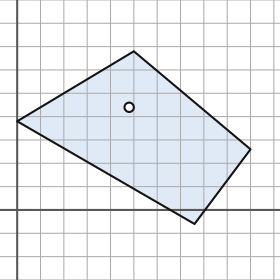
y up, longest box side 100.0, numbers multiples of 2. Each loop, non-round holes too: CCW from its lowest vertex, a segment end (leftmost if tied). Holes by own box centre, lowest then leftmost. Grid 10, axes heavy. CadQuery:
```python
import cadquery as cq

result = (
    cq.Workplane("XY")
    .moveTo(76.0, -6.0)
    .lineTo(100.0, 26.0)
    .lineTo(50.0, 68.0)
    .lineTo(0.0, 38.0)
    .close()
    .moveTo(48.0, 44.0)
    .circle(2.0)
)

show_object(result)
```